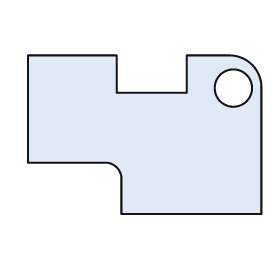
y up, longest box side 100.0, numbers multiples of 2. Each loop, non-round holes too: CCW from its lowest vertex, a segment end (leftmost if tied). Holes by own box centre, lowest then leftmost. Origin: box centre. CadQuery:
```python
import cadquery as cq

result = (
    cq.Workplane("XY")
    .moveTo(-10.0, -34.0)
    .lineTo(50.0, -34.0)
    .lineTo(50.0, 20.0)
    .threePointArc((46.0, 30.0), (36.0, 34.0))
    .lineTo(18.0, 34.0)
    .lineTo(18.0, 18.0)
    .lineTo(-12.0, 18.0)
    .lineTo(-12.0, 34.0)
    .lineTo(-50.0, 34.0)
    .lineTo(-50.0, -12.0)
    .lineTo(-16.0, -12.0)
    .threePointArc((-12.0, -14.0), (-10.0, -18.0))
    .close()
    .moveTo(38.0, 20.0)
    .circle(8.0)
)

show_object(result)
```